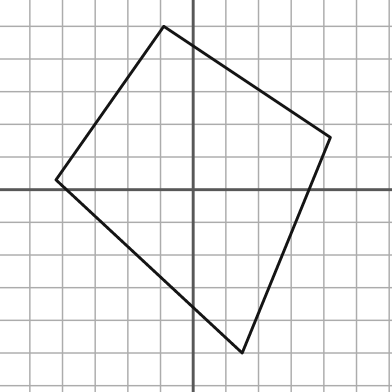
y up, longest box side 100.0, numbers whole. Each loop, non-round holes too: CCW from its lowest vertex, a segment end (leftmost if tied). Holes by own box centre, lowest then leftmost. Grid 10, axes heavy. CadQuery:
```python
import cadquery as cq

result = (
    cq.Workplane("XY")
    .moveTo(15.0, -50.0)
    .lineTo(42.0, 16.0)
    .lineTo(-9.0, 50.0)
    .lineTo(-42.0, 3.0)
    .close()
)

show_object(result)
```